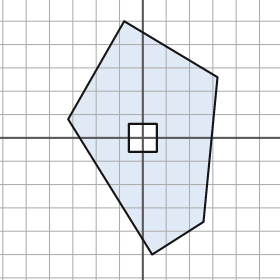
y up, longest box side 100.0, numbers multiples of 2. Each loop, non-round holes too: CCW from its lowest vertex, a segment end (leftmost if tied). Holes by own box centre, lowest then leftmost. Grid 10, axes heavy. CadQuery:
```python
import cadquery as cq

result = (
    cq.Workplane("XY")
    .moveTo(4.0, -50.0)
    .lineTo(26.0, -36.0)
    .lineTo(32.0, 26.0)
    .lineTo(-8.0, 50.0)
    .lineTo(-32.0, 8.0)
    .close()
    .moveTo(-6.0, -6.0)
    .lineTo(6.0, -6.0)
    .lineTo(6.0, 6.0)
    .lineTo(-6.0, 6.0)
    .close()
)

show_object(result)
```